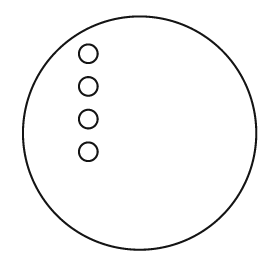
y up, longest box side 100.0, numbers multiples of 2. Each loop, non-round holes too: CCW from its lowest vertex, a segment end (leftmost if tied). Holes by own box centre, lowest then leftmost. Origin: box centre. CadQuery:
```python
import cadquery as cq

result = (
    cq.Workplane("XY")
    .moveTo(0.0, 0.0)
    .circle(50.0)
    .moveTo(-22.0, -8.0)
    .circle(4.0)
    .moveTo(-22.0, 6.0)
    .circle(4.0)
    .moveTo(-22.0, 20.0)
    .circle(4.0)
    .moveTo(-22.0, 34.0)
    .circle(4.0)
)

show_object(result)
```